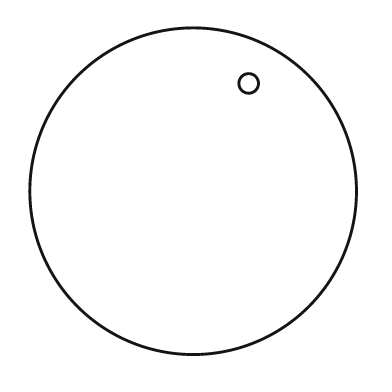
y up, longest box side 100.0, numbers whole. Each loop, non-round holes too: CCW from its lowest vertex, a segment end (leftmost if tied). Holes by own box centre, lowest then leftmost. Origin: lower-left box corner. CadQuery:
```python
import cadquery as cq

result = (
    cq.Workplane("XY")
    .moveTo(50.0, 50.0)
    .circle(50.0)
    .moveTo(67.0, 83.0)
    .circle(3.0)
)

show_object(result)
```